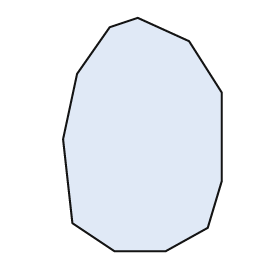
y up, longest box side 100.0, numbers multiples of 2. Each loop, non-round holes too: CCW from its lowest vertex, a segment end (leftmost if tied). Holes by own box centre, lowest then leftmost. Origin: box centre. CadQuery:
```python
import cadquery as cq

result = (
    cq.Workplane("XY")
    .moveTo(-12.0, -50.0)
    .lineTo(10.0, -50.0)
    .lineTo(28.0, -40.0)
    .lineTo(34.0, -20.0)
    .lineTo(34.0, 18.0)
    .lineTo(20.0, 40.0)
    .lineTo(-2.0, 50.0)
    .lineTo(-14.0, 46.0)
    .lineTo(-28.0, 26.0)
    .lineTo(-34.0, -2.0)
    .lineTo(-30.0, -38.0)
    .close()
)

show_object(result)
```